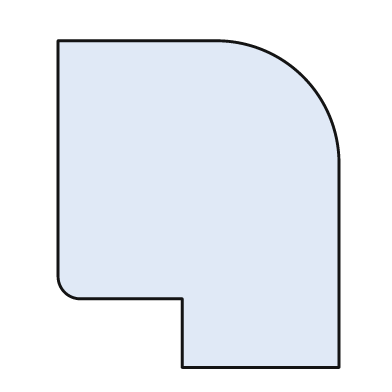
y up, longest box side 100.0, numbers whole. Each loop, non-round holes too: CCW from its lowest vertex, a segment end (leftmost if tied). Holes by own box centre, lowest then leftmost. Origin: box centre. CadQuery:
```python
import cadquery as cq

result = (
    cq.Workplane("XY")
    .moveTo(-5.0, -50.0)
    .lineTo(43.0, -50.0)
    .lineTo(43.0, 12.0)
    .threePointArc((32.0, 39.0), (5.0, 50.0))
    .lineTo(-43.0, 50.0)
    .lineTo(-43.0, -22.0)
    .threePointArc((-41.0, -27.0), (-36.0, -29.0))
    .lineTo(-5.0, -29.0)
    .close()
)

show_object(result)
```